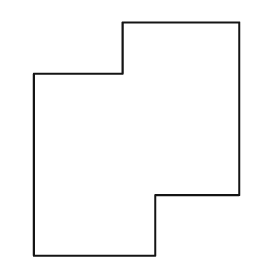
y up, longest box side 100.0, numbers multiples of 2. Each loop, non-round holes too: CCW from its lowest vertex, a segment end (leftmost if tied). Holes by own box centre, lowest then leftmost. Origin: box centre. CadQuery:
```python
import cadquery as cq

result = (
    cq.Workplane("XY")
    .moveTo(-44.0, -50.0)
    .lineTo(8.0, -50.0)
    .lineTo(8.0, -24.0)
    .lineTo(44.0, -24.0)
    .lineTo(44.0, 50.0)
    .lineTo(-6.0, 50.0)
    .lineTo(-6.0, 28.0)
    .lineTo(-44.0, 28.0)
    .close()
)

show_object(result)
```